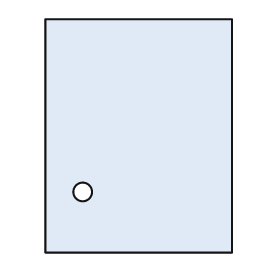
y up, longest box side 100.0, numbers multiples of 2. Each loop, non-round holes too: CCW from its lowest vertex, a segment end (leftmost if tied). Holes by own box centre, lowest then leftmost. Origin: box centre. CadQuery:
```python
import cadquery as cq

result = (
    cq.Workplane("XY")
    .moveTo(-40.0, -50.0)
    .lineTo(40.0, -50.0)
    .lineTo(40.0, 50.0)
    .lineTo(-40.0, 50.0)
    .close()
    .moveTo(-24.0, -24.0)
    .circle(4.0)
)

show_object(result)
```